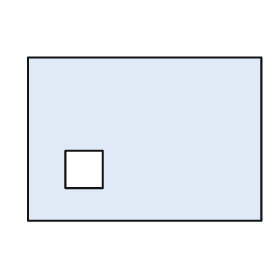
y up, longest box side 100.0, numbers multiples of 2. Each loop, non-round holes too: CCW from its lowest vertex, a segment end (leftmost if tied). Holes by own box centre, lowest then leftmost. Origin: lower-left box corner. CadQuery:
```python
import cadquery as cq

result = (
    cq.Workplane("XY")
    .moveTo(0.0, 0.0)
    .lineTo(100.0, 0.0)
    .lineTo(100.0, 70.0)
    .lineTo(0.0, 70.0)
    .close()
    .moveTo(16.0, 14.0)
    .lineTo(32.0, 14.0)
    .lineTo(32.0, 30.0)
    .lineTo(16.0, 30.0)
    .close()
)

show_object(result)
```